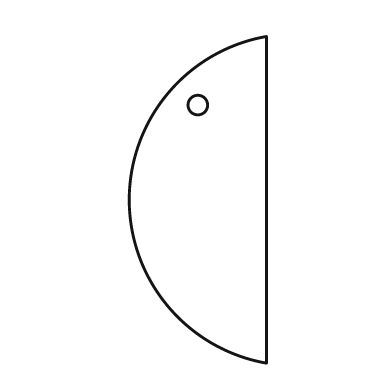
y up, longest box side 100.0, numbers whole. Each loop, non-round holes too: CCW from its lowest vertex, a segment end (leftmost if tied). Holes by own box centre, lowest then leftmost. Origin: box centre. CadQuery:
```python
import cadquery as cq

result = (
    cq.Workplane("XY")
    .moveTo(21.0, -50.0)
    .lineTo(21.0, 50.0)
    .threePointArc((-21.0, 0.0), (21.0, -50.0))
    .close()
    .moveTo(0.0, 29.0)
    .circle(3.0)
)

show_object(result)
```